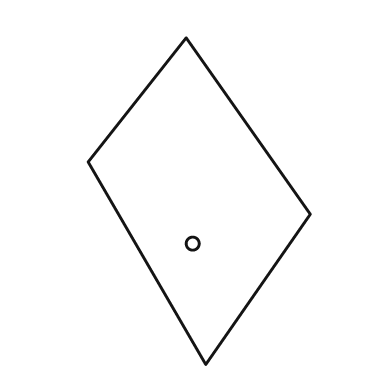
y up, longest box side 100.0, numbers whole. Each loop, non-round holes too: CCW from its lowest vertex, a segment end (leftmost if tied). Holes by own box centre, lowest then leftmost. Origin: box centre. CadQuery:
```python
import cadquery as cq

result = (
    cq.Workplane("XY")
    .moveTo(2.0, -50.0)
    .lineTo(34.0, -4.0)
    .lineTo(-4.0, 50.0)
    .lineTo(-34.0, 12.0)
    .close()
    .moveTo(-2.0, -13.0)
    .circle(2.0)
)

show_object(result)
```